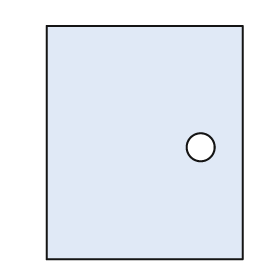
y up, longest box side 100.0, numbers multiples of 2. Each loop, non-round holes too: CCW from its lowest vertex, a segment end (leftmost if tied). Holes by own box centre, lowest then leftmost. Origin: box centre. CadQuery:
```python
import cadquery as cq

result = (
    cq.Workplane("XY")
    .moveTo(-42.0, -50.0)
    .lineTo(42.0, -50.0)
    .lineTo(42.0, 50.0)
    .lineTo(-42.0, 50.0)
    .close()
    .moveTo(24.0, -2.0)
    .circle(6.0)
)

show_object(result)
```